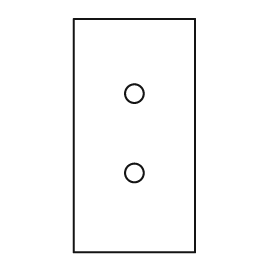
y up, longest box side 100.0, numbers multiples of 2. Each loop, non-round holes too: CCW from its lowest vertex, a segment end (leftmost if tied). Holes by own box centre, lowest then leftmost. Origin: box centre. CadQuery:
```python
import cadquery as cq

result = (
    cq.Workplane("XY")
    .moveTo(-26.0, -50.0)
    .lineTo(26.0, -50.0)
    .lineTo(26.0, 50.0)
    .lineTo(-26.0, 50.0)
    .close()
    .moveTo(0.0, -16.0)
    .circle(4.0)
    .moveTo(0.0, 18.0)
    .circle(4.0)
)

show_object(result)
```